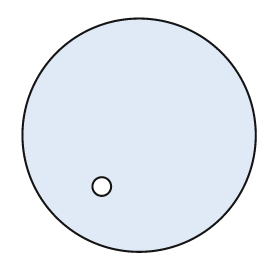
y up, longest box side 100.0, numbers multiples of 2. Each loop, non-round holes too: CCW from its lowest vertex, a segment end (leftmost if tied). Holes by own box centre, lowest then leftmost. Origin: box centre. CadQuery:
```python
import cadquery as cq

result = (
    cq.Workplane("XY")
    .moveTo(0.0, 0.0)
    .circle(50.0)
    .moveTo(-16.0, -22.0)
    .circle(4.0)
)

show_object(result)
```